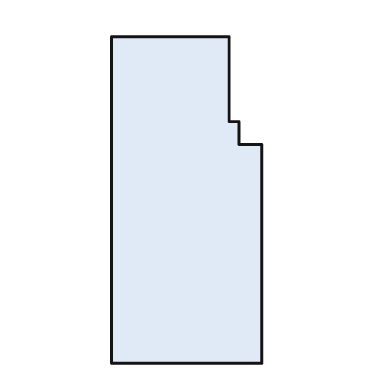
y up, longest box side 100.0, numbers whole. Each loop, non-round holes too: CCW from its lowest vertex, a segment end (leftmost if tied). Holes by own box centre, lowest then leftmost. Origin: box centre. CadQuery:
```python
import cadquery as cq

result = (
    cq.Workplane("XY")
    .moveTo(-23.0, -50.0)
    .lineTo(23.0, -50.0)
    .lineTo(23.0, 17.0)
    .lineTo(16.0, 17.0)
    .lineTo(16.0, 24.0)
    .lineTo(13.0, 24.0)
    .lineTo(13.0, 50.0)
    .lineTo(-23.0, 50.0)
    .close()
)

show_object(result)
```